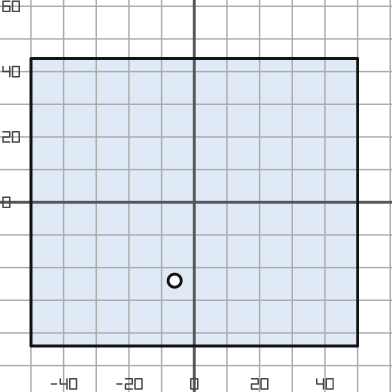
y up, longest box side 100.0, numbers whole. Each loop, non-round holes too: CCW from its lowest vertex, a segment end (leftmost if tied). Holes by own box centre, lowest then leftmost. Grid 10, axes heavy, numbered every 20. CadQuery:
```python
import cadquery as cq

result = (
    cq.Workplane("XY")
    .moveTo(-50.0, -44.0)
    .lineTo(50.0, -44.0)
    .lineTo(50.0, 44.0)
    .lineTo(-50.0, 44.0)
    .close()
    .moveTo(-6.0, -24.0)
    .circle(2.0)
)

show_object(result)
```